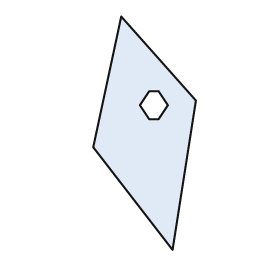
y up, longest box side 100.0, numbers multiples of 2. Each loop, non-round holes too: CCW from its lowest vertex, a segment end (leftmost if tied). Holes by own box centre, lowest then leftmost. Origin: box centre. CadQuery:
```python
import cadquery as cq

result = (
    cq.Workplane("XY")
    .moveTo(12.0, -50.0)
    .lineTo(22.0, 14.0)
    .lineTo(-10.0, 50.0)
    .lineTo(-22.0, -6.0)
    .close()
    .moveTo(2.0, 6.0)
    .lineTo(6.0, 6.0)
    .lineTo(10.0, 12.0)
    .lineTo(6.0, 18.0)
    .lineTo(2.0, 18.0)
    .lineTo(-2.0, 12.0)
    .close()
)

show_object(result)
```